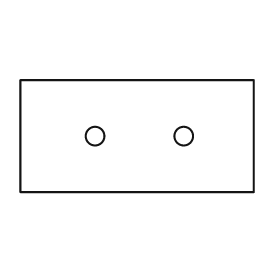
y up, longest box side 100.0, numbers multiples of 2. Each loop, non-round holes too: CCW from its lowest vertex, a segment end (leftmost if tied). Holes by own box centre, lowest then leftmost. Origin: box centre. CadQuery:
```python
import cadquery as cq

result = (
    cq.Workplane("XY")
    .moveTo(-50.0, -24.0)
    .lineTo(50.0, -24.0)
    .lineTo(50.0, 24.0)
    .lineTo(-50.0, 24.0)
    .close()
    .moveTo(-18.0, 0.0)
    .circle(4.0)
    .moveTo(20.0, 0.0)
    .circle(4.0)
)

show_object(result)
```